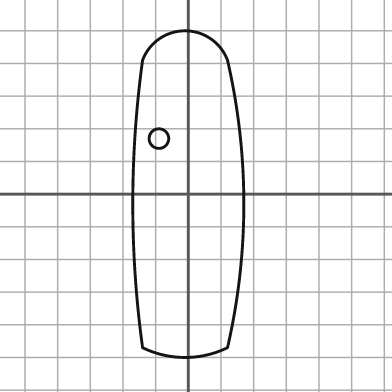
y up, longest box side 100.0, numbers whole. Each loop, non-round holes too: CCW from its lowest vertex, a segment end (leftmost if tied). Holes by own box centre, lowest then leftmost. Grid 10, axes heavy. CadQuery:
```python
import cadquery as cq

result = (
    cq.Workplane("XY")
    .moveTo(-14.0, -47.0)
    .threePointArc((-1.0, -50.0), (12.0, -47.0))
    .threePointArc((17.0, -3.0), (12.0, 41.0))
    .threePointArc((-1.0, 50.0), (-14.0, 41.0))
    .threePointArc((-17.0, -3.0), (-14.0, -47.0))
    .close()
    .moveTo(-9.0, 17.0)
    .circle(3.0)
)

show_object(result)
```